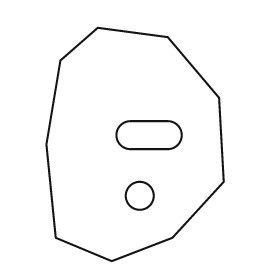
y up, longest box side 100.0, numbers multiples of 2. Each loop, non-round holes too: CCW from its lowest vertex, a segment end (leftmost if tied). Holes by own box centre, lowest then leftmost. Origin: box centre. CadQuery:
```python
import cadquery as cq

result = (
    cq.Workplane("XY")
    .moveTo(-10.0, -50.0)
    .lineTo(16.0, -40.0)
    .lineTo(38.0, -16.0)
    .lineTo(36.0, 20.0)
    .lineTo(14.0, 46.0)
    .lineTo(-16.0, 50.0)
    .lineTo(-32.0, 36.0)
    .lineTo(-38.0, 0.0)
    .lineTo(-34.0, -40.0)
    .close()
    .moveTo(2.0, -22.0)
    .circle(6.0)
    .moveTo(-2.0, -2.0)
    .lineTo(14.0, -2.0)
    .threePointArc((20.0, 4.0), (14.0, 10.0))
    .lineTo(-2.0, 10.0)
    .threePointArc((-8.0, 4.0), (-2.0, -2.0))
    .close()
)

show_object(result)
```